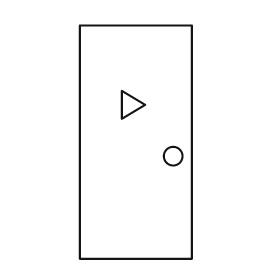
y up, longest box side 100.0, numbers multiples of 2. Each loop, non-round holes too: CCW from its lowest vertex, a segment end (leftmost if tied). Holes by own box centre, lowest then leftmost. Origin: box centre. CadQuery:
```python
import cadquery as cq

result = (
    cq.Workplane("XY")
    .moveTo(-24.0, -50.0)
    .lineTo(24.0, -50.0)
    .lineTo(24.0, 50.0)
    .lineTo(-24.0, 50.0)
    .close()
    .moveTo(16.0, -6.0)
    .circle(4.0)
    .moveTo(-6.0, 10.0)
    .lineTo(4.0, 16.0)
    .lineTo(-6.0, 22.0)
    .close()
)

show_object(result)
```